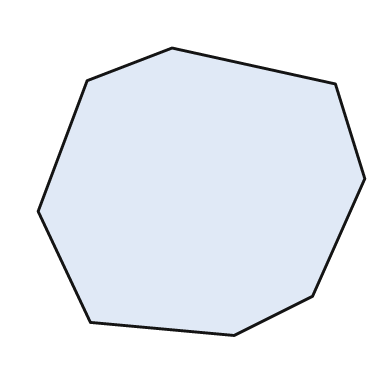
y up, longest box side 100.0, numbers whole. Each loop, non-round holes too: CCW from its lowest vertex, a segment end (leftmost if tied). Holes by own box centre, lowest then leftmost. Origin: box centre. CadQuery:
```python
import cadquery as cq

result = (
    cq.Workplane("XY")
    .moveTo(10.0, -44.0)
    .lineTo(34.0, -32.0)
    .lineTo(50.0, 4.0)
    .lineTo(41.0, 33.0)
    .lineTo(-9.0, 44.0)
    .lineTo(-35.0, 34.0)
    .lineTo(-50.0, -6.0)
    .lineTo(-34.0, -40.0)
    .close()
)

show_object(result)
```